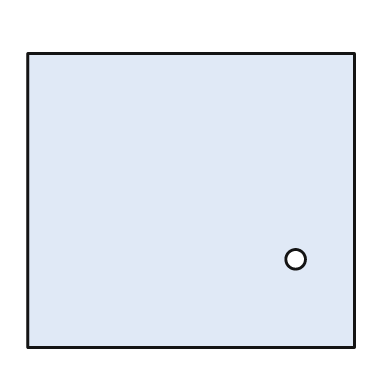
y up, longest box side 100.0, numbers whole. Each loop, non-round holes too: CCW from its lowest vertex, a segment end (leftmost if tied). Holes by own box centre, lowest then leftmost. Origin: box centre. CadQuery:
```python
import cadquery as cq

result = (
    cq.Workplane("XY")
    .moveTo(-50.0, -45.0)
    .lineTo(50.0, -45.0)
    .lineTo(50.0, 45.0)
    .lineTo(-50.0, 45.0)
    .close()
    .moveTo(32.0, -18.0)
    .circle(3.0)
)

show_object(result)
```